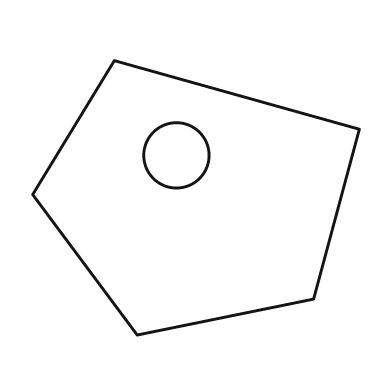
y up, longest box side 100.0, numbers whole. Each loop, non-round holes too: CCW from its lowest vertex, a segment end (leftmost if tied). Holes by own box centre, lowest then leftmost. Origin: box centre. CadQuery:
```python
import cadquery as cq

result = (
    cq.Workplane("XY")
    .moveTo(-18.0, -42.0)
    .lineTo(36.0, -31.0)
    .lineTo(50.0, 21.0)
    .lineTo(-25.0, 42.0)
    .lineTo(-50.0, 1.0)
    .close()
    .moveTo(-6.0, 13.0)
    .circle(10.0)
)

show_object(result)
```